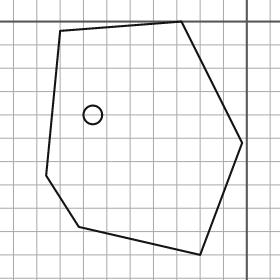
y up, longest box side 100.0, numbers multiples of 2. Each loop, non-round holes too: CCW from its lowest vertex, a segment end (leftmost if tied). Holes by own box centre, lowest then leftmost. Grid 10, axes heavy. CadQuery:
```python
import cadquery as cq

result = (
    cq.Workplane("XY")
    .moveTo(-20.0, -100.0)
    .lineTo(-2.0, -52.0)
    .lineTo(-28.0, 0.0)
    .lineTo(-80.0, -4.0)
    .lineTo(-86.0, -66.0)
    .lineTo(-72.0, -88.0)
    .close()
    .moveTo(-66.0, -40.0)
    .circle(4.0)
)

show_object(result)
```